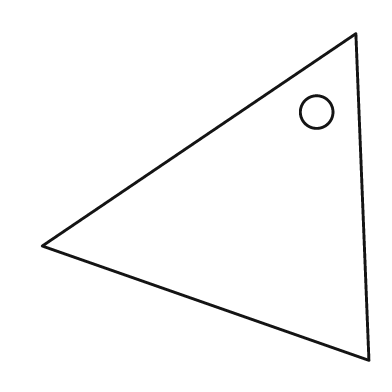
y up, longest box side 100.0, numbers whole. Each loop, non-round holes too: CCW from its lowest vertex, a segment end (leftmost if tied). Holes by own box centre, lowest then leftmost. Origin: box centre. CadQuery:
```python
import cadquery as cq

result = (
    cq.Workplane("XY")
    .moveTo(50.0, -50.0)
    .lineTo(46.0, 50.0)
    .lineTo(-50.0, -15.0)
    .close()
    .moveTo(34.0, 26.0)
    .circle(5.0)
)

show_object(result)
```